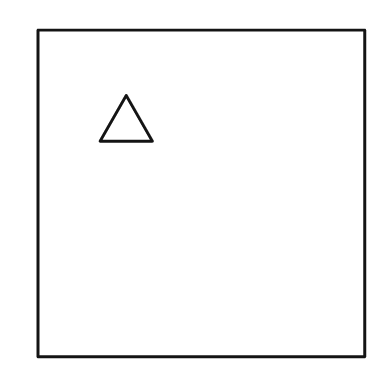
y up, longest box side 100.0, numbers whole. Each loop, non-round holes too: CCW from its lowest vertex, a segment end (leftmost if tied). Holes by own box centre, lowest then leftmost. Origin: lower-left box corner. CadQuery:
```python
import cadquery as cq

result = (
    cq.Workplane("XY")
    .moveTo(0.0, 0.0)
    .lineTo(100.0, 0.0)
    .lineTo(100.0, 100.0)
    .lineTo(0.0, 100.0)
    .close()
    .moveTo(19.0, 66.0)
    .lineTo(35.0, 66.0)
    .lineTo(27.0, 80.0)
    .close()
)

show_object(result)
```